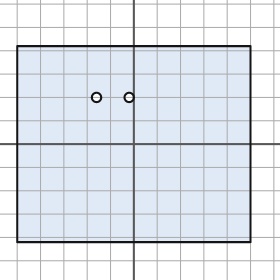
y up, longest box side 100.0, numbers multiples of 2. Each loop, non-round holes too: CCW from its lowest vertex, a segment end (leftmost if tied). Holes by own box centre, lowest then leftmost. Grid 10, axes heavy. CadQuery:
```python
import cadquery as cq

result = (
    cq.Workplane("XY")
    .moveTo(-50.0, -42.0)
    .lineTo(50.0, -42.0)
    .lineTo(50.0, 42.0)
    .lineTo(-50.0, 42.0)
    .close()
    .moveTo(-16.0, 20.0)
    .circle(2.0)
    .moveTo(-2.0, 20.0)
    .circle(2.0)
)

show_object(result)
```